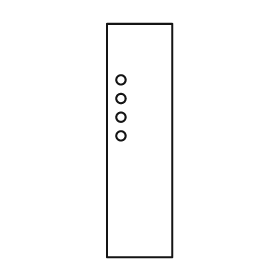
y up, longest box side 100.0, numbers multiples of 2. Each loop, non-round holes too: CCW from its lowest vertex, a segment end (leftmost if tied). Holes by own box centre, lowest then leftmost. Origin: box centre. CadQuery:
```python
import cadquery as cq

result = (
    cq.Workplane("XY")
    .moveTo(-14.0, -50.0)
    .lineTo(14.0, -50.0)
    .lineTo(14.0, 50.0)
    .lineTo(-14.0, 50.0)
    .close()
    .moveTo(-8.0, 2.0)
    .circle(2.0)
    .moveTo(-8.0, 10.0)
    .circle(2.0)
    .moveTo(-8.0, 18.0)
    .circle(2.0)
    .moveTo(-8.0, 26.0)
    .circle(2.0)
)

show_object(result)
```